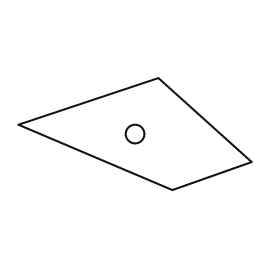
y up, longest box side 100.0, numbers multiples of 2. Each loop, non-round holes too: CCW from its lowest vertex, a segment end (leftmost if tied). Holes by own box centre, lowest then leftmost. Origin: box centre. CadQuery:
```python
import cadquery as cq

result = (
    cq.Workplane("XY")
    .moveTo(16.0, -24.0)
    .lineTo(50.0, -12.0)
    .lineTo(10.0, 24.0)
    .lineTo(-50.0, 4.0)
    .close()
    .moveTo(0.0, 0.0)
    .circle(4.0)
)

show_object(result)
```